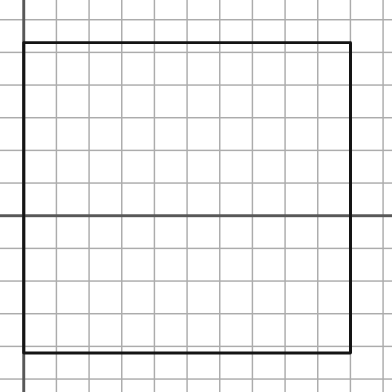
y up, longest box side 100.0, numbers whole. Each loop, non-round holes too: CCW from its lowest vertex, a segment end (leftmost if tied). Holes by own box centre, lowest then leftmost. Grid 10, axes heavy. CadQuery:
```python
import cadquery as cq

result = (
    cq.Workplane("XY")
    .moveTo(0.0, -42.0)
    .lineTo(100.0, -42.0)
    .lineTo(100.0, 53.0)
    .lineTo(0.0, 53.0)
    .close()
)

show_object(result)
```